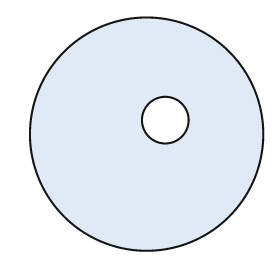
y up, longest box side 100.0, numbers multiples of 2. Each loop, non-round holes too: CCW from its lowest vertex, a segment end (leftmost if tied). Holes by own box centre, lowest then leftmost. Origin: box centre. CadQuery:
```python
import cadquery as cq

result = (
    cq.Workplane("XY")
    .moveTo(0.0, 0.0)
    .circle(50.0)
    .moveTo(8.0, 6.0)
    .circle(10.0)
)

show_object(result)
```